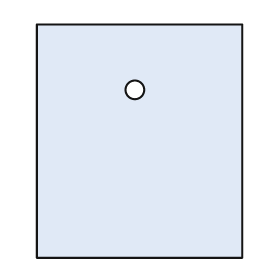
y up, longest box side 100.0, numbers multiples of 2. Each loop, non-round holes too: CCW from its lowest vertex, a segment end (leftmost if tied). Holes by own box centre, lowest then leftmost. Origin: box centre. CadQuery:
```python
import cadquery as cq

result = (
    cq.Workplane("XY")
    .moveTo(-44.0, -50.0)
    .lineTo(44.0, -50.0)
    .lineTo(44.0, 50.0)
    .lineTo(-44.0, 50.0)
    .close()
    .moveTo(-2.0, 22.0)
    .circle(4.0)
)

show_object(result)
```